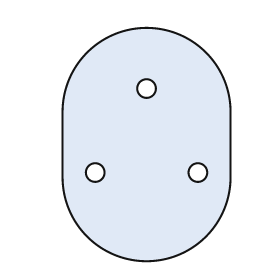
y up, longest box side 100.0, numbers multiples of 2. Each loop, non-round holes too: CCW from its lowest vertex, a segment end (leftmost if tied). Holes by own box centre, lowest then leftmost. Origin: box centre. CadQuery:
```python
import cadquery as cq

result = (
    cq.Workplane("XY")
    .moveTo(-36.0, -14.0)
    .threePointArc((0.0, -50.0), (36.0, -14.0))
    .lineTo(36.0, 14.0)
    .threePointArc((0.0, 50.0), (-36.0, 14.0))
    .close()
    .moveTo(-22.0, -12.0)
    .circle(4.0)
    .moveTo(22.0, -12.0)
    .circle(4.0)
    .moveTo(0.0, 24.0)
    .circle(4.0)
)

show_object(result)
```